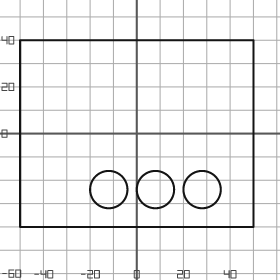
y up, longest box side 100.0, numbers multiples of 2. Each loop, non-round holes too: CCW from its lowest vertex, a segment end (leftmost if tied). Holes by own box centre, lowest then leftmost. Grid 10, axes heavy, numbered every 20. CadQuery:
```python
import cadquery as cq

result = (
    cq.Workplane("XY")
    .moveTo(-50.0, -40.0)
    .lineTo(50.0, -40.0)
    .lineTo(50.0, 40.0)
    .lineTo(-50.0, 40.0)
    .close()
    .moveTo(-12.0, -24.0)
    .circle(8.0)
    .moveTo(8.0, -24.0)
    .circle(8.0)
    .moveTo(28.0, -24.0)
    .circle(8.0)
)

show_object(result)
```